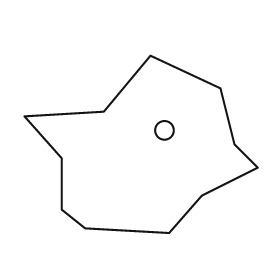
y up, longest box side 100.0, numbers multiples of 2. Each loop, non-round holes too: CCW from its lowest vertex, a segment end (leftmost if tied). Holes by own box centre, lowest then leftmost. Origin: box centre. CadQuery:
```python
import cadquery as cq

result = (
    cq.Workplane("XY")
    .moveTo(12.0, -38.0)
    .lineTo(26.0, -22.0)
    .lineTo(50.0, -10.0)
    .lineTo(40.0, 0.0)
    .lineTo(34.0, 24.0)
    .lineTo(4.0, 38.0)
    .lineTo(-16.0, 14.0)
    .lineTo(-50.0, 12.0)
    .lineTo(-34.0, -6.0)
    .lineTo(-34.0, -28.0)
    .lineTo(-24.0, -36.0)
    .close()
    .moveTo(10.0, 6.0)
    .circle(4.0)
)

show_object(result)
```